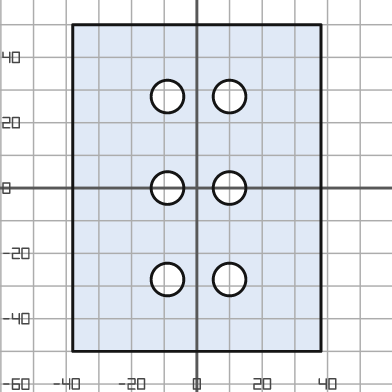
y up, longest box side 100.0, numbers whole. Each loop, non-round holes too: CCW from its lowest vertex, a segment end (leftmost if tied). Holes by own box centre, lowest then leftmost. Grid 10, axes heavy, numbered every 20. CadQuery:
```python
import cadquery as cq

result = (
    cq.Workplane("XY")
    .moveTo(-38.0, -50.0)
    .lineTo(38.0, -50.0)
    .lineTo(38.0, 50.0)
    .lineTo(-38.0, 50.0)
    .close()
    .moveTo(-9.0, -28.0)
    .circle(5.0)
    .moveTo(10.0, -28.0)
    .circle(5.0)
    .moveTo(-9.0, 0.0)
    .circle(5.0)
    .moveTo(10.0, 0.0)
    .circle(5.0)
    .moveTo(-9.0, 28.0)
    .circle(5.0)
    .moveTo(10.0, 28.0)
    .circle(5.0)
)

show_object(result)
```